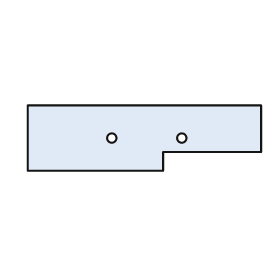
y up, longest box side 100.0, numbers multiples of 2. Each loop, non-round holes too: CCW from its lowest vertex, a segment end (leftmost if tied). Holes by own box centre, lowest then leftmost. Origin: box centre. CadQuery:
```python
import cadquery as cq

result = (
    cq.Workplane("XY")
    .moveTo(-50.0, -14.0)
    .lineTo(8.0, -14.0)
    .lineTo(8.0, -6.0)
    .lineTo(50.0, -6.0)
    .lineTo(50.0, 14.0)
    .lineTo(-50.0, 14.0)
    .close()
    .moveTo(-14.0, 0.0)
    .circle(2.0)
    .moveTo(16.0, 0.0)
    .circle(2.0)
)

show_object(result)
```